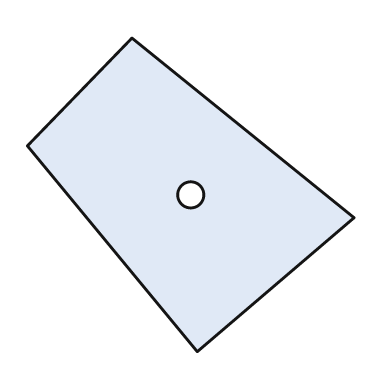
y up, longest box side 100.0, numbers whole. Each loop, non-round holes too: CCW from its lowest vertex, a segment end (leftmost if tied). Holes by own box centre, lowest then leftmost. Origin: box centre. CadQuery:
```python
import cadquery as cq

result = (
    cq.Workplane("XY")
    .moveTo(2.0, -48.0)
    .lineTo(50.0, -7.0)
    .lineTo(-18.0, 48.0)
    .lineTo(-50.0, 15.0)
    .close()
    .moveTo(0.0, 0.0)
    .circle(4.0)
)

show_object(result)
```